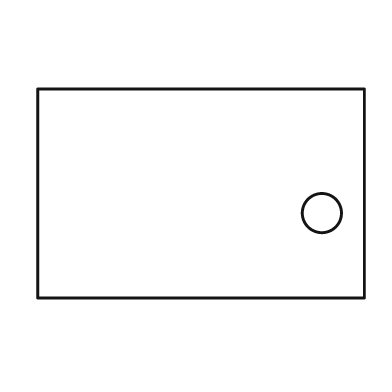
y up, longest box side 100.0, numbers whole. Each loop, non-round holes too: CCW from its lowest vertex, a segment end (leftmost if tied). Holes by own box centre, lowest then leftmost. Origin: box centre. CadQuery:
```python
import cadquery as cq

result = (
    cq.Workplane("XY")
    .moveTo(-50.0, -32.0)
    .lineTo(50.0, -32.0)
    .lineTo(50.0, 32.0)
    .lineTo(-50.0, 32.0)
    .close()
    .moveTo(37.0, -6.0)
    .circle(6.0)
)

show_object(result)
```